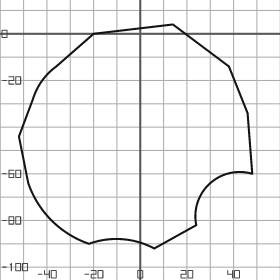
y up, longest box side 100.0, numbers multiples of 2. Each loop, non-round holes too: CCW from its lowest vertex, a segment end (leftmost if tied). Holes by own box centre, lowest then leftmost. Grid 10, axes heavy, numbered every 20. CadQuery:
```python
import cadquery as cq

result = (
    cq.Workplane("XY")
    .moveTo(6.0, -92.0)
    .lineTo(24.0, -82.0)
    .threePointArc((30.0, -64.0), (48.0, -60.0))
    .lineTo(46.0, -34.0)
    .lineTo(38.0, -14.0)
    .lineTo(14.0, 4.0)
    .lineTo(-20.0, 0.0)
    .lineTo(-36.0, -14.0)
    .threePointArc((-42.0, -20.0), (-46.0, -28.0))
    .lineTo(-52.0, -44.0)
    .lineTo(-48.0, -64.0)
    .threePointArc((-38.0, -80.0), (-22.0, -90.0))
    .threePointArc((-8.0, -88.0), (6.0, -92.0))
    .close()
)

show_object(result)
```